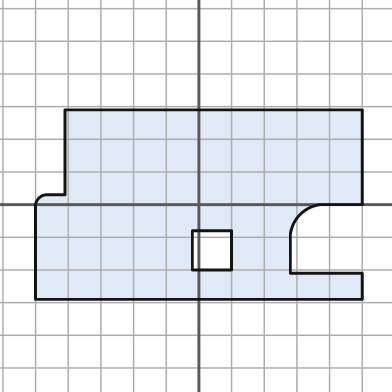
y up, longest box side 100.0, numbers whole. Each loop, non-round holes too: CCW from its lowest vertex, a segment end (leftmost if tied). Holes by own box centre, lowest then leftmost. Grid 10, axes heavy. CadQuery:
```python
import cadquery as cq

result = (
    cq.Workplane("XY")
    .moveTo(-50.0, -29.0)
    .lineTo(50.0, -29.0)
    .lineTo(50.0, -21.0)
    .lineTo(28.0, -21.0)
    .lineTo(28.0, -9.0)
    .threePointArc((31.0, -3.0), (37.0, 0.0))
    .lineTo(50.0, 0.0)
    .lineTo(50.0, 29.0)
    .lineTo(-41.0, 29.0)
    .lineTo(-41.0, 3.0)
    .lineTo(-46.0, 3.0)
    .threePointArc((-49.0, 2.0), (-50.0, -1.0))
    .close()
    .moveTo(-2.0, -20.0)
    .lineTo(10.0, -20.0)
    .lineTo(10.0, -8.0)
    .lineTo(-2.0, -8.0)
    .close()
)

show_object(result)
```